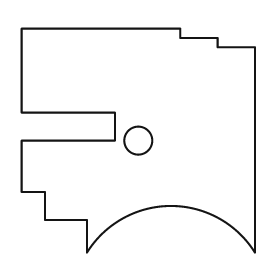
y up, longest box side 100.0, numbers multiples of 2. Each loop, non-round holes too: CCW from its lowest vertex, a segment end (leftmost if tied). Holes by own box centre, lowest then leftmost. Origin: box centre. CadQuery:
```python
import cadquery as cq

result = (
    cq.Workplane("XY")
    .moveTo(-22.0, -48.0)
    .threePointArc((14.0, -28.0), (50.0, -48.0))
    .lineTo(50.0, 40.0)
    .lineTo(34.0, 40.0)
    .lineTo(34.0, 44.0)
    .lineTo(18.0, 44.0)
    .lineTo(18.0, 48.0)
    .lineTo(-50.0, 48.0)
    .lineTo(-50.0, 12.0)
    .lineTo(-10.0, 12.0)
    .lineTo(-10.0, 0.0)
    .lineTo(-50.0, 0.0)
    .lineTo(-50.0, -22.0)
    .lineTo(-40.0, -22.0)
    .lineTo(-40.0, -34.0)
    .lineTo(-22.0, -34.0)
    .close()
    .moveTo(0.0, 0.0)
    .circle(6.0)
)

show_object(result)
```